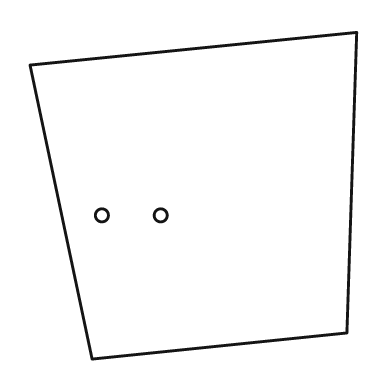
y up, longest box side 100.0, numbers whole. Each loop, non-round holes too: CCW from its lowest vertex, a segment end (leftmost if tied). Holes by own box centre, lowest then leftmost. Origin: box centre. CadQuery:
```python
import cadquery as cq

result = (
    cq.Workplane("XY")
    .moveTo(-31.0, -50.0)
    .lineTo(47.0, -42.0)
    .lineTo(50.0, 50.0)
    .lineTo(-50.0, 40.0)
    .close()
    .moveTo(-28.0, -6.0)
    .circle(2.0)
    .moveTo(-10.0, -6.0)
    .circle(2.0)
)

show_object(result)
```